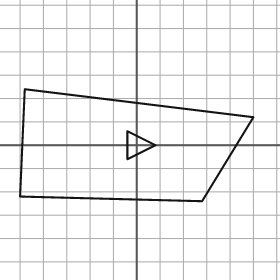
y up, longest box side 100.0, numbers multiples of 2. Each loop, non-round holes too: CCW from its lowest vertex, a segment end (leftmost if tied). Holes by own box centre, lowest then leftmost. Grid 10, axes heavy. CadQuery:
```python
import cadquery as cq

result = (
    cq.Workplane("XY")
    .moveTo(28.0, -24.0)
    .lineTo(50.0, 12.0)
    .lineTo(-48.0, 24.0)
    .lineTo(-50.0, -22.0)
    .close()
    .moveTo(-4.0, -6.0)
    .lineTo(8.0, 0.0)
    .lineTo(-4.0, 6.0)
    .close()
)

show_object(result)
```